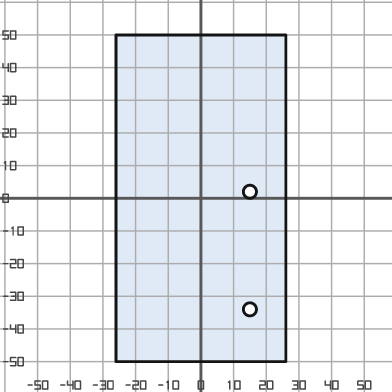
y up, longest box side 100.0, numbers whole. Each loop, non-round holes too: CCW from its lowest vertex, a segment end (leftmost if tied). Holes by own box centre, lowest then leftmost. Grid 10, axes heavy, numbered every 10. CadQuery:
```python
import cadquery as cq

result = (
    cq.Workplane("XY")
    .moveTo(-26.0, -50.0)
    .lineTo(26.0, -50.0)
    .lineTo(26.0, 50.0)
    .lineTo(-26.0, 50.0)
    .close()
    .moveTo(15.0, -34.0)
    .circle(2.0)
    .moveTo(15.0, 2.0)
    .circle(2.0)
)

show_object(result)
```